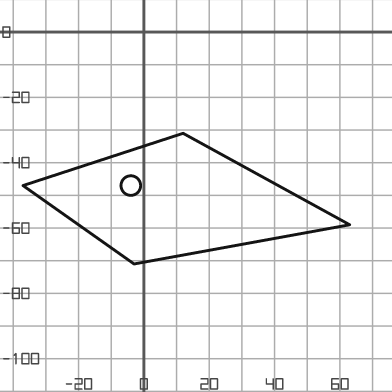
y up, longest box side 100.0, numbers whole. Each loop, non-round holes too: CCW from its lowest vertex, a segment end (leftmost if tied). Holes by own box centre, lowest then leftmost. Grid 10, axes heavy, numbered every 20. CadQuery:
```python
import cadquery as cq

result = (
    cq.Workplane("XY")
    .moveTo(-3.0, -71.0)
    .lineTo(63.0, -59.0)
    .lineTo(12.0, -31.0)
    .lineTo(-37.0, -47.0)
    .close()
    .moveTo(-4.0, -47.0)
    .circle(3.0)
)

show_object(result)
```